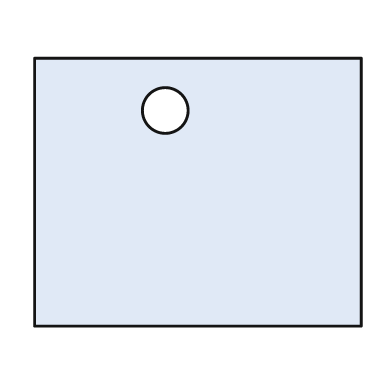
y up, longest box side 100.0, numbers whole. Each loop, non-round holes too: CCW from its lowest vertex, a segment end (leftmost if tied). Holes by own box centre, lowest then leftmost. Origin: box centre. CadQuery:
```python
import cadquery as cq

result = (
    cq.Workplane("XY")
    .moveTo(-50.0, -41.0)
    .lineTo(50.0, -41.0)
    .lineTo(50.0, 41.0)
    .lineTo(-50.0, 41.0)
    .close()
    .moveTo(-10.0, 25.0)
    .circle(7.0)
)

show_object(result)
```